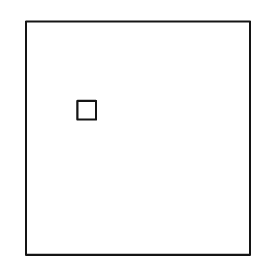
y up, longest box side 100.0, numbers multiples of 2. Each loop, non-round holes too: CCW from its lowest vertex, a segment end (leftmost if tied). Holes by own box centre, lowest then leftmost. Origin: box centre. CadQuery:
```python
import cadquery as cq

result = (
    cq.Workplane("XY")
    .moveTo(-48.0, -50.0)
    .lineTo(48.0, -50.0)
    .lineTo(48.0, 50.0)
    .lineTo(-48.0, 50.0)
    .close()
    .moveTo(-26.0, 8.0)
    .lineTo(-18.0, 8.0)
    .lineTo(-18.0, 16.0)
    .lineTo(-26.0, 16.0)
    .close()
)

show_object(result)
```